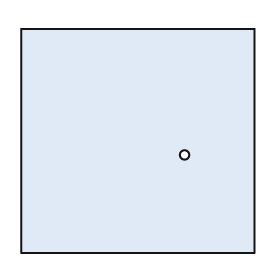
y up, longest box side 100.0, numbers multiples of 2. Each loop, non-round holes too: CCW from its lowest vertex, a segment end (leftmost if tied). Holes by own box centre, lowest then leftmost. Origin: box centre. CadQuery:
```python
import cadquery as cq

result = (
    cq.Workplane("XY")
    .moveTo(-50.0, -48.0)
    .lineTo(50.0, -48.0)
    .lineTo(50.0, 48.0)
    .lineTo(-50.0, 48.0)
    .close()
    .moveTo(20.0, -6.0)
    .circle(2.0)
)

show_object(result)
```